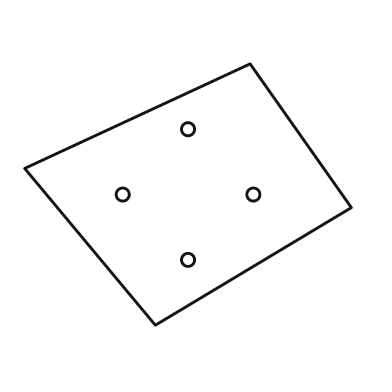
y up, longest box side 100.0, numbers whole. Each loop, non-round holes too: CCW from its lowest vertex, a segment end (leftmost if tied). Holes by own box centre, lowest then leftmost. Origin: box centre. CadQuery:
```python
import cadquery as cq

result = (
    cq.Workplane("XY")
    .moveTo(-10.0, -40.0)
    .lineTo(50.0, -4.0)
    .lineTo(19.0, 40.0)
    .lineTo(-50.0, 8.0)
    .close()
    .moveTo(0.0, -20.0)
    .circle(2.0)
    .moveTo(-20.0, 0.0)
    .circle(2.0)
    .moveTo(20.0, 0.0)
    .circle(2.0)
    .moveTo(0.0, 20.0)
    .circle(2.0)
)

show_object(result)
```